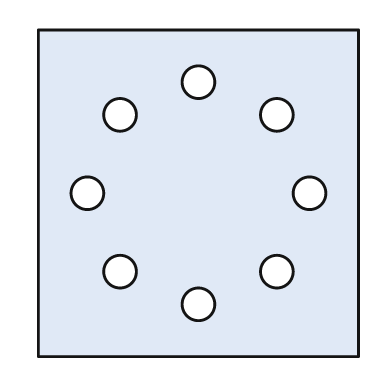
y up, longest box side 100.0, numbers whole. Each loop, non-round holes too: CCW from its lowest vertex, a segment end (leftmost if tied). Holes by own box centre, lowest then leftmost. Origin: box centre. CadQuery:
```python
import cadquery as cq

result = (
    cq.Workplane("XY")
    .moveTo(-49.0, -50.0)
    .lineTo(49.0, -50.0)
    .lineTo(49.0, 50.0)
    .lineTo(-49.0, 50.0)
    .close()
    .moveTo(0.0, -34.0)
    .circle(5.0)
    .moveTo(-24.0, -24.0)
    .circle(5.0)
    .moveTo(24.0, -24.0)
    .circle(5.0)
    .moveTo(-34.0, 0.0)
    .circle(5.0)
    .moveTo(34.0, 0.0)
    .circle(5.0)
    .moveTo(-24.0, 24.0)
    .circle(5.0)
    .moveTo(24.0, 24.0)
    .circle(5.0)
    .moveTo(0.0, 34.0)
    .circle(5.0)
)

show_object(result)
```